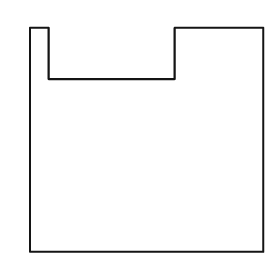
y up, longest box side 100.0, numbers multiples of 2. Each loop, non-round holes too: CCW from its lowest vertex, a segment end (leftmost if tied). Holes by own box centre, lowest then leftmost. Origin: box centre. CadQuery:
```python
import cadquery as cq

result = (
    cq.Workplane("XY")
    .moveTo(-50.0, -48.0)
    .lineTo(50.0, -48.0)
    .lineTo(50.0, 48.0)
    .lineTo(12.0, 48.0)
    .lineTo(12.0, 26.0)
    .lineTo(-42.0, 26.0)
    .lineTo(-42.0, 48.0)
    .lineTo(-50.0, 48.0)
    .close()
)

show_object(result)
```